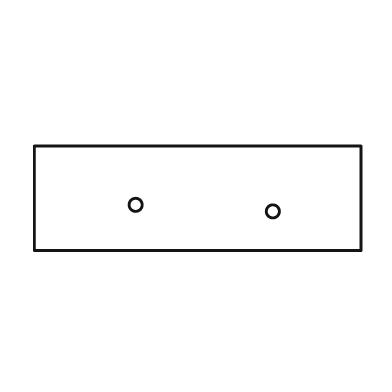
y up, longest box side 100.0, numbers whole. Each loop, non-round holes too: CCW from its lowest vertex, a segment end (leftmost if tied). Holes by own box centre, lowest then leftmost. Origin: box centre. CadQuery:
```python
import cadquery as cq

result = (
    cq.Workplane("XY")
    .moveTo(-50.0, -16.0)
    .lineTo(50.0, -16.0)
    .lineTo(50.0, 16.0)
    .lineTo(-50.0, 16.0)
    .close()
    .moveTo(23.0, -4.0)
    .circle(2.0)
    .moveTo(-19.0, -2.0)
    .circle(2.0)
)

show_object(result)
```